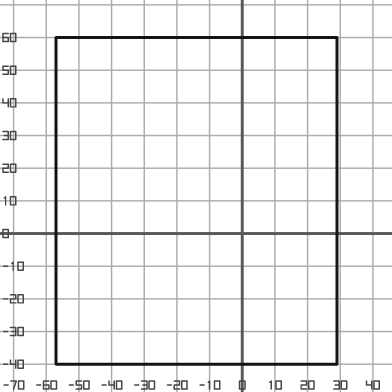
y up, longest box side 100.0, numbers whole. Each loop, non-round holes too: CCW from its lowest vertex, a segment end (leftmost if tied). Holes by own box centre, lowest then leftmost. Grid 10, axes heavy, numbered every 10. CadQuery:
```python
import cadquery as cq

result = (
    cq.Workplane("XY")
    .moveTo(-57.0, -40.0)
    .lineTo(29.0, -40.0)
    .lineTo(29.0, 60.0)
    .lineTo(-57.0, 60.0)
    .close()
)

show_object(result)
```